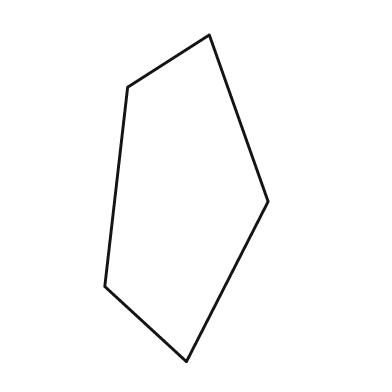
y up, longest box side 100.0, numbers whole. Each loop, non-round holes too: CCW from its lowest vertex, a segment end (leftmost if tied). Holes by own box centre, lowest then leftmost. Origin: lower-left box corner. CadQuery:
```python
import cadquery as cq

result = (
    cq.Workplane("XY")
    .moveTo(25.0, 0.0)
    .lineTo(50.0, 49.0)
    .lineTo(32.0, 100.0)
    .lineTo(7.0, 84.0)
    .lineTo(0.0, 23.0)
    .close()
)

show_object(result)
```